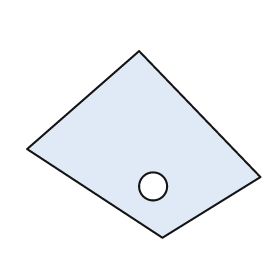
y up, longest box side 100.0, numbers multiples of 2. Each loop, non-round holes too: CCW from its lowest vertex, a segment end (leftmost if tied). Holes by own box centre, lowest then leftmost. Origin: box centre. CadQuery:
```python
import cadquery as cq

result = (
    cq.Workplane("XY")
    .moveTo(8.0, -40.0)
    .lineTo(50.0, -14.0)
    .lineTo(-2.0, 40.0)
    .lineTo(-50.0, -2.0)
    .close()
    .moveTo(4.0, -18.0)
    .circle(6.0)
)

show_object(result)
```